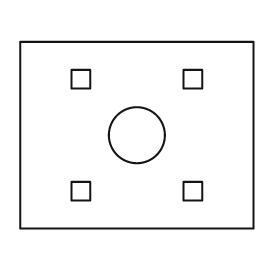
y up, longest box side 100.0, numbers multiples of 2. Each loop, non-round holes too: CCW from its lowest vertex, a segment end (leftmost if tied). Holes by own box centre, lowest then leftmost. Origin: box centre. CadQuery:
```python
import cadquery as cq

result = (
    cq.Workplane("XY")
    .moveTo(-50.0, -40.0)
    .lineTo(50.0, -40.0)
    .lineTo(50.0, 40.0)
    .lineTo(-50.0, 40.0)
    .close()
    .moveTo(-28.0, -28.0)
    .lineTo(-20.0, -28.0)
    .lineTo(-20.0, -20.0)
    .lineTo(-28.0, -20.0)
    .close()
    .moveTo(20.0, -28.0)
    .lineTo(28.0, -28.0)
    .lineTo(28.0, -20.0)
    .lineTo(20.0, -20.0)
    .close()
    .moveTo(0.0, 0.0)
    .circle(12.0)
    .moveTo(-28.0, 20.0)
    .lineTo(-20.0, 20.0)
    .lineTo(-20.0, 28.0)
    .lineTo(-28.0, 28.0)
    .close()
    .moveTo(20.0, 20.0)
    .lineTo(28.0, 20.0)
    .lineTo(28.0, 28.0)
    .lineTo(20.0, 28.0)
    .close()
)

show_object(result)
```